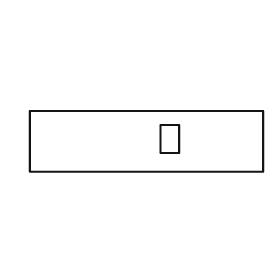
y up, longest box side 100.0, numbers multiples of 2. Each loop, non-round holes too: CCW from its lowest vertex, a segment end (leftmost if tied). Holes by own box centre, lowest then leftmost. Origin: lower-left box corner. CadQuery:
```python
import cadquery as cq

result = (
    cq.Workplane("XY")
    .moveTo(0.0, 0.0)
    .lineTo(100.0, 0.0)
    .lineTo(100.0, 26.0)
    .lineTo(0.0, 26.0)
    .close()
    .moveTo(56.0, 8.0)
    .lineTo(64.0, 8.0)
    .lineTo(64.0, 20.0)
    .lineTo(56.0, 20.0)
    .close()
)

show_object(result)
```